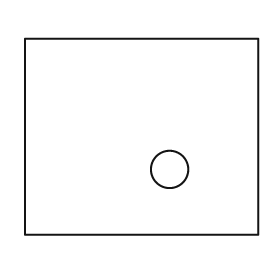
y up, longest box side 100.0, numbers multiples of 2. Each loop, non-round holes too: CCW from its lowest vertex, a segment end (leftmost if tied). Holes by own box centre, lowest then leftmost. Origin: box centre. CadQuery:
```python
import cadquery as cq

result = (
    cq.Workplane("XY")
    .moveTo(-50.0, -42.0)
    .lineTo(50.0, -42.0)
    .lineTo(50.0, 42.0)
    .lineTo(-50.0, 42.0)
    .close()
    .moveTo(12.0, -14.0)
    .circle(8.0)
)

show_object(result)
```